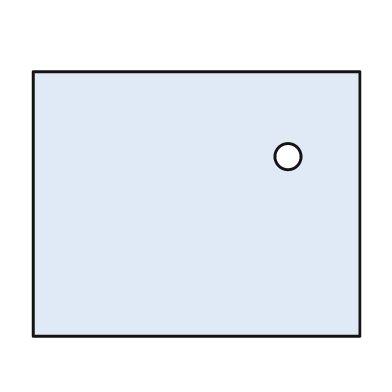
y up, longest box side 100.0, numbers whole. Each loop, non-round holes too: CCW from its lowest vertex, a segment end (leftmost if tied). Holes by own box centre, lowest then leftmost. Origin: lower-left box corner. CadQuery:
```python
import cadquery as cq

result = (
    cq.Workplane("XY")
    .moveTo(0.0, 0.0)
    .lineTo(100.0, 0.0)
    .lineTo(100.0, 81.0)
    .lineTo(0.0, 81.0)
    .close()
    .moveTo(78.0, 55.0)
    .circle(4.0)
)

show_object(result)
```